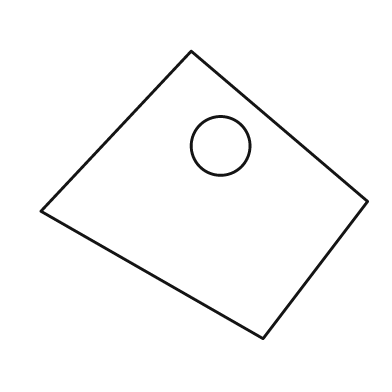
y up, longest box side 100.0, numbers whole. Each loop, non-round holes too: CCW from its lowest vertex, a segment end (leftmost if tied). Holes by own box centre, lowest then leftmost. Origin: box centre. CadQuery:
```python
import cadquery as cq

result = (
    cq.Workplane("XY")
    .moveTo(18.0, -44.0)
    .lineTo(50.0, -2.0)
    .lineTo(-4.0, 44.0)
    .lineTo(-50.0, -5.0)
    .close()
    .moveTo(5.0, 15.0)
    .circle(9.0)
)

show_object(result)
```